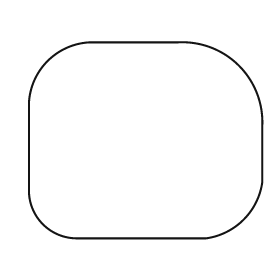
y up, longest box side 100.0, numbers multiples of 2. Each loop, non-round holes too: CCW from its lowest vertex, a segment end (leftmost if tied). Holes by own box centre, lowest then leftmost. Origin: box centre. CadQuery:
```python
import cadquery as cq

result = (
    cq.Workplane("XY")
    .moveTo(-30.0, -42.0)
    .lineTo(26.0, -42.0)
    .threePointArc((42.0, -34.0), (50.0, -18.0))
    .lineTo(50.0, 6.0)
    .threePointArc((40.0, 32.0), (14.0, 42.0))
    .lineTo(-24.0, 42.0)
    .threePointArc((-42.0, 34.0), (-50.0, 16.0))
    .lineTo(-50.0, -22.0)
    .threePointArc((-44.0, -36.0), (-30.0, -42.0))
    .close()
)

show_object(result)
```